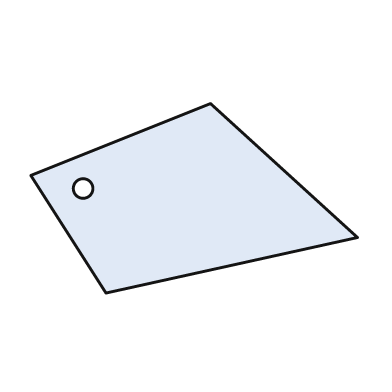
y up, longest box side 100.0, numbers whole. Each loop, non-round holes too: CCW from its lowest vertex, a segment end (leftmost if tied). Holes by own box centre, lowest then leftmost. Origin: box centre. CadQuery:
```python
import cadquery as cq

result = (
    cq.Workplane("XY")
    .moveTo(-27.0, -29.0)
    .lineTo(50.0, -12.0)
    .lineTo(5.0, 29.0)
    .lineTo(-50.0, 7.0)
    .close()
    .moveTo(-34.0, 3.0)
    .circle(3.0)
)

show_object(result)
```